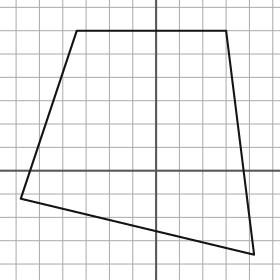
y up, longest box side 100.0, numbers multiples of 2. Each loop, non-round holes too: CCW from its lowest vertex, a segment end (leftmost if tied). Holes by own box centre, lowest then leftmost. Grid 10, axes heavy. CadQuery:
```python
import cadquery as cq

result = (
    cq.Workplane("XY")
    .moveTo(42.0, -36.0)
    .lineTo(30.0, 60.0)
    .lineTo(-34.0, 60.0)
    .lineTo(-58.0, -12.0)
    .close()
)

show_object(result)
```